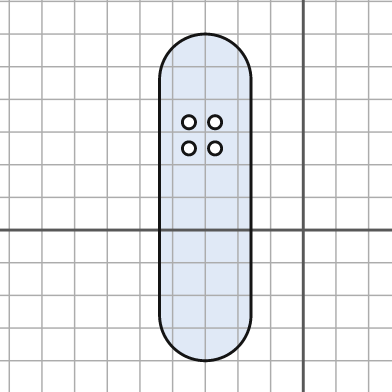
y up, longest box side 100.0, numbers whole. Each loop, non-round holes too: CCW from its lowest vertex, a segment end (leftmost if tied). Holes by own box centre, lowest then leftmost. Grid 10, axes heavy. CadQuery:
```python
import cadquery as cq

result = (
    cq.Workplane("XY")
    .moveTo(-44.0, -26.0)
    .threePointArc((-30.0, -40.0), (-16.0, -26.0))
    .lineTo(-16.0, 46.0)
    .threePointArc((-30.0, 60.0), (-44.0, 46.0))
    .close()
    .moveTo(-35.0, 25.0)
    .circle(2.0)
    .moveTo(-27.0, 25.0)
    .circle(2.0)
    .moveTo(-35.0, 33.0)
    .circle(2.0)
    .moveTo(-27.0, 33.0)
    .circle(2.0)
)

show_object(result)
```